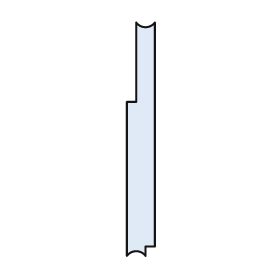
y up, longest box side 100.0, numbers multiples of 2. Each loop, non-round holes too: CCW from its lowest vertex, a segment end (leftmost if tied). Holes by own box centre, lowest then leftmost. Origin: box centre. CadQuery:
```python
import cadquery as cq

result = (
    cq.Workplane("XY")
    .moveTo(-6.0, -50.0)
    .threePointArc((-2.0, -48.0), (2.0, -50.0))
    .lineTo(2.0, -46.0)
    .lineTo(6.0, -46.0)
    .lineTo(6.0, 50.0)
    .threePointArc((2.0, 48.0), (-2.0, 50.0))
    .lineTo(-2.0, 16.0)
    .lineTo(-6.0, 16.0)
    .close()
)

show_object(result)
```